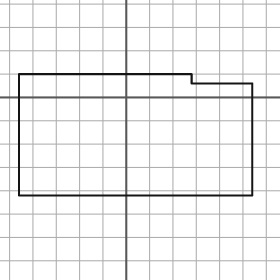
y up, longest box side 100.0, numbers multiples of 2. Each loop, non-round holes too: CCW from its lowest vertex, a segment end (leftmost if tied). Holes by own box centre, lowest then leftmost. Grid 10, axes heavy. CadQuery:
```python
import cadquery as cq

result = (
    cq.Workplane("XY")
    .moveTo(-46.0, -42.0)
    .lineTo(54.0, -42.0)
    .lineTo(54.0, 6.0)
    .lineTo(28.0, 6.0)
    .lineTo(28.0, 10.0)
    .lineTo(-46.0, 10.0)
    .close()
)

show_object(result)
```